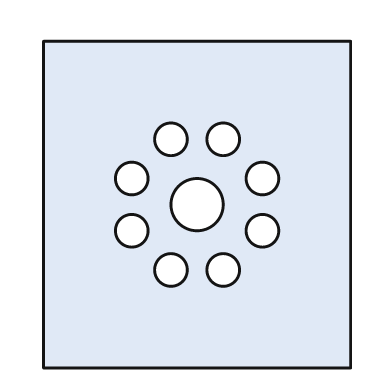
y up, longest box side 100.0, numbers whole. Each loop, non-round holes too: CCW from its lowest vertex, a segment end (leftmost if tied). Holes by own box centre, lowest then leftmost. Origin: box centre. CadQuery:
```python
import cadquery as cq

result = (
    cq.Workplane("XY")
    .moveTo(-47.0, -50.0)
    .lineTo(47.0, -50.0)
    .lineTo(47.0, 50.0)
    .lineTo(-47.0, 50.0)
    .close()
    .moveTo(-8.0, -20.0)
    .circle(5.0)
    .moveTo(8.0, -20.0)
    .circle(5.0)
    .moveTo(-20.0, -8.0)
    .circle(5.0)
    .moveTo(20.0, -8.0)
    .circle(5.0)
    .moveTo(0.0, 0.0)
    .circle(8.0)
    .moveTo(-20.0, 8.0)
    .circle(5.0)
    .moveTo(20.0, 8.0)
    .circle(5.0)
    .moveTo(-8.0, 20.0)
    .circle(5.0)
    .moveTo(8.0, 20.0)
    .circle(5.0)
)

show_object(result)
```